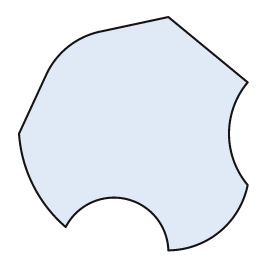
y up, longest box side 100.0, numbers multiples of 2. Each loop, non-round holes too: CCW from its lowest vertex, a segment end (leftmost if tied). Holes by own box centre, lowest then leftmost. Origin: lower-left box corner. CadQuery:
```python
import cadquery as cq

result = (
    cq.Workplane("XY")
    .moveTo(64.0, 0.0)
    .threePointArc((86.0, 8.0), (98.0, 28.0))
    .threePointArc((90.0, 50.0), (98.0, 72.0))
    .lineTo(64.0, 100.0)
    .lineTo(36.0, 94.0)
    .threePointArc((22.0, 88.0), (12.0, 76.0))
    .lineTo(0.0, 50.0)
    .threePointArc((6.0, 28.0), (20.0, 10.0))
    .threePointArc((46.0, 22.0), (64.0, 0.0))
    .close()
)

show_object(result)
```